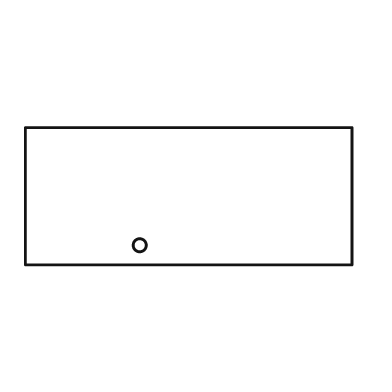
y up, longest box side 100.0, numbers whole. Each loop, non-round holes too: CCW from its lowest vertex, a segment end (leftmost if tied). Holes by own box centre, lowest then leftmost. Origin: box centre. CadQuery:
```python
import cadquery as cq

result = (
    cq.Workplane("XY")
    .moveTo(-50.0, -21.0)
    .lineTo(50.0, -21.0)
    .lineTo(50.0, 21.0)
    .lineTo(-50.0, 21.0)
    .close()
    .moveTo(-15.0, -15.0)
    .circle(2.0)
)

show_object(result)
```